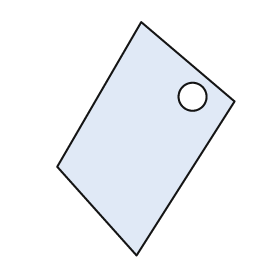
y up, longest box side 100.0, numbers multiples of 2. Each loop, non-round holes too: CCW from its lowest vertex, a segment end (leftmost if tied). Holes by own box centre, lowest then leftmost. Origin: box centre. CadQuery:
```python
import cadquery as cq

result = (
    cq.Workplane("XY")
    .moveTo(-4.0, -50.0)
    .lineTo(38.0, 16.0)
    .lineTo(-2.0, 50.0)
    .lineTo(-38.0, -12.0)
    .close()
    .moveTo(20.0, 18.0)
    .circle(6.0)
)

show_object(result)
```